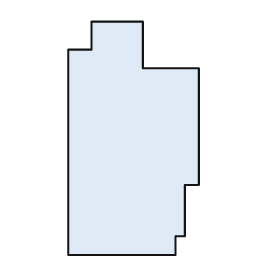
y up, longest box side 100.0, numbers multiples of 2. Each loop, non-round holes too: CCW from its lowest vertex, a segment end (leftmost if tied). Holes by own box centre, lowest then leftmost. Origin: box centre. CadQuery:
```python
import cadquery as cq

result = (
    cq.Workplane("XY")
    .moveTo(-28.0, -50.0)
    .lineTo(18.0, -50.0)
    .lineTo(18.0, -42.0)
    .lineTo(22.0, -42.0)
    .lineTo(22.0, -20.0)
    .lineTo(28.0, -20.0)
    .lineTo(28.0, 30.0)
    .lineTo(4.0, 30.0)
    .lineTo(4.0, 50.0)
    .lineTo(-18.0, 50.0)
    .lineTo(-18.0, 38.0)
    .lineTo(-28.0, 38.0)
    .close()
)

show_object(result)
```